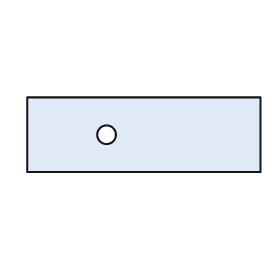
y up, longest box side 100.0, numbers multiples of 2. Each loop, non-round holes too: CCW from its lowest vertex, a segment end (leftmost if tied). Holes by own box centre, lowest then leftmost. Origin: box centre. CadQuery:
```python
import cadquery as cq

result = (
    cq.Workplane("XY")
    .moveTo(-50.0, -16.0)
    .lineTo(50.0, -16.0)
    .lineTo(50.0, 16.0)
    .lineTo(-50.0, 16.0)
    .close()
    .moveTo(-16.0, 0.0)
    .circle(4.0)
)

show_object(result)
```